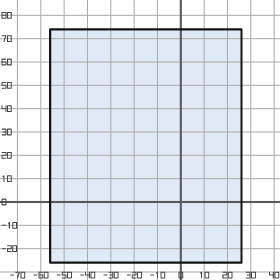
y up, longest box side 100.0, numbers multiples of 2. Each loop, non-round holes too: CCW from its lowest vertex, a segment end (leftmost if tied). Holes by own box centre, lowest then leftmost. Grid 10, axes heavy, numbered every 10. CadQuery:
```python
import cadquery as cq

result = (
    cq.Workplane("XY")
    .moveTo(-56.0, -26.0)
    .lineTo(26.0, -26.0)
    .lineTo(26.0, 74.0)
    .lineTo(-56.0, 74.0)
    .close()
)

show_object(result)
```